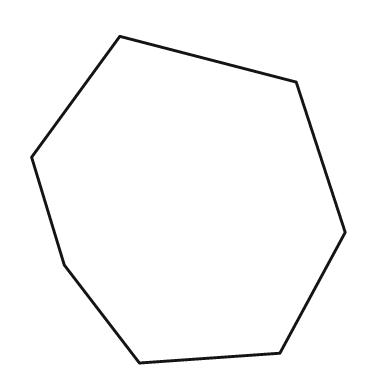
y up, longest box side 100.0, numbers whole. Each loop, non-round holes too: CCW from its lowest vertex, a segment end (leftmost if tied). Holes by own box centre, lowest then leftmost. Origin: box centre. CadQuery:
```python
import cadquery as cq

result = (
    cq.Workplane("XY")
    .moveTo(-15.0, -50.0)
    .lineTo(28.0, -47.0)
    .lineTo(48.0, -10.0)
    .lineTo(33.0, 36.0)
    .lineTo(-21.0, 50.0)
    .lineTo(-48.0, 13.0)
    .lineTo(-38.0, -20.0)
    .close()
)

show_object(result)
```